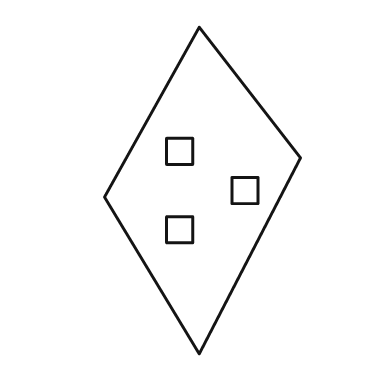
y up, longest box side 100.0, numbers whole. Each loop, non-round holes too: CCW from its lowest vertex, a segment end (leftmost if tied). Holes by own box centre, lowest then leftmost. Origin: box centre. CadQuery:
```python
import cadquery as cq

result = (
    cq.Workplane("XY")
    .moveTo(-1.0, -50.0)
    .lineTo(30.0, 10.0)
    .lineTo(-1.0, 50.0)
    .lineTo(-30.0, -2.0)
    .close()
    .moveTo(-11.0, -16.0)
    .lineTo(-3.0, -16.0)
    .lineTo(-3.0, -8.0)
    .lineTo(-11.0, -8.0)
    .close()
    .moveTo(9.0, -4.0)
    .lineTo(17.0, -4.0)
    .lineTo(17.0, 4.0)
    .lineTo(9.0, 4.0)
    .close()
    .moveTo(-11.0, 8.0)
    .lineTo(-3.0, 8.0)
    .lineTo(-3.0, 16.0)
    .lineTo(-11.0, 16.0)
    .close()
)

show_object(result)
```